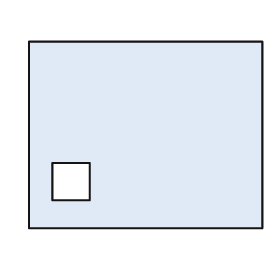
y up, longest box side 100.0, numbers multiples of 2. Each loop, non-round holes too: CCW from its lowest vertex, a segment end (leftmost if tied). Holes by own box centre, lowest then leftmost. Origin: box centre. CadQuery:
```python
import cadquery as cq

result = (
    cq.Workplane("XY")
    .moveTo(-50.0, -40.0)
    .lineTo(50.0, -40.0)
    .lineTo(50.0, 40.0)
    .lineTo(-50.0, 40.0)
    .close()
    .moveTo(-40.0, -28.0)
    .lineTo(-24.0, -28.0)
    .lineTo(-24.0, -12.0)
    .lineTo(-40.0, -12.0)
    .close()
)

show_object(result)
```